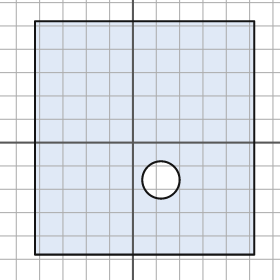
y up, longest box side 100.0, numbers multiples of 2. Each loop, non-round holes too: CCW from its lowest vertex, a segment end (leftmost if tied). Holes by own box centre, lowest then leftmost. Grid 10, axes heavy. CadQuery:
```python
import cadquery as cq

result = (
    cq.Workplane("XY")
    .moveTo(-42.0, -48.0)
    .lineTo(52.0, -48.0)
    .lineTo(52.0, 52.0)
    .lineTo(-42.0, 52.0)
    .close()
    .moveTo(12.0, -16.0)
    .circle(8.0)
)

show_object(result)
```